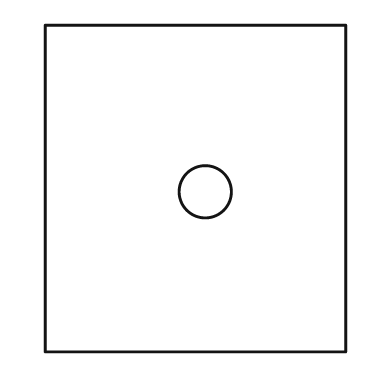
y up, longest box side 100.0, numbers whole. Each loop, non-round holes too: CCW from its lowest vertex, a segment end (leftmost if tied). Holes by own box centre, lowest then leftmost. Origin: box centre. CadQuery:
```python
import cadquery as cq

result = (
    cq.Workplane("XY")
    .moveTo(-46.0, -50.0)
    .lineTo(46.0, -50.0)
    .lineTo(46.0, 50.0)
    .lineTo(-46.0, 50.0)
    .close()
    .moveTo(3.0, -1.0)
    .circle(8.0)
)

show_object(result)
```